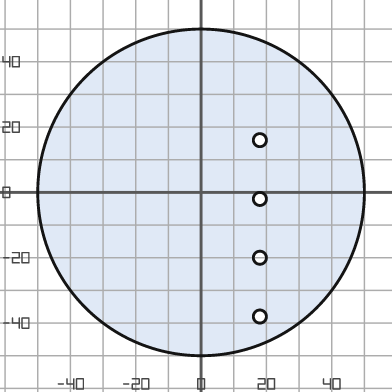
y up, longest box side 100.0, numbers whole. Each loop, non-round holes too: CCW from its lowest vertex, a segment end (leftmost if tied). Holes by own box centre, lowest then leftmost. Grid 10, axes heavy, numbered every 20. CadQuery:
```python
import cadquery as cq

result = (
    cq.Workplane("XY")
    .moveTo(0.0, 0.0)
    .circle(50.0)
    .moveTo(18.0, -38.0)
    .circle(2.0)
    .moveTo(18.0, -20.0)
    .circle(2.0)
    .moveTo(18.0, -2.0)
    .circle(2.0)
    .moveTo(18.0, 16.0)
    .circle(2.0)
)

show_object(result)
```